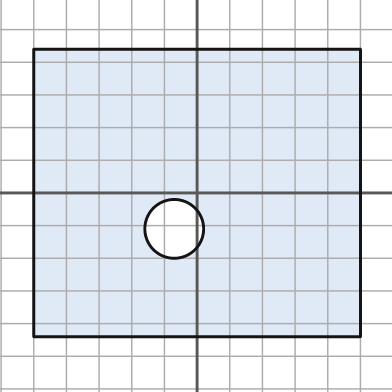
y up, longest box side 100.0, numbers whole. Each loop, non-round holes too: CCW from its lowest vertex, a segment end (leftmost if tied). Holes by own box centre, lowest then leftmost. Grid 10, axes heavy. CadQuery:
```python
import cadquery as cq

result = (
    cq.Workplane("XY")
    .moveTo(-50.0, -44.0)
    .lineTo(50.0, -44.0)
    .lineTo(50.0, 44.0)
    .lineTo(-50.0, 44.0)
    .close()
    .moveTo(-7.0, -11.0)
    .circle(9.0)
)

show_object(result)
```